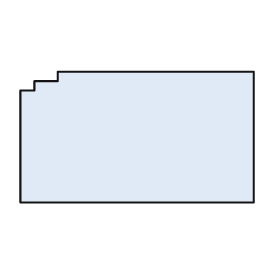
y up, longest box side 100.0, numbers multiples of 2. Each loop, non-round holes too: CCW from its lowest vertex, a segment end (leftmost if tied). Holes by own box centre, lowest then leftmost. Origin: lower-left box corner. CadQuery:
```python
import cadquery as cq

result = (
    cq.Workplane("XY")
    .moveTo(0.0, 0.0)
    .lineTo(100.0, 0.0)
    .lineTo(100.0, 56.0)
    .lineTo(16.0, 56.0)
    .lineTo(16.0, 52.0)
    .lineTo(6.0, 52.0)
    .lineTo(6.0, 48.0)
    .lineTo(0.0, 48.0)
    .close()
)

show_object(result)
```